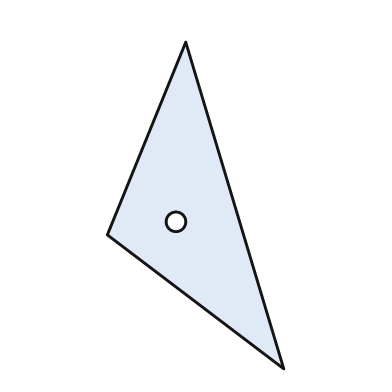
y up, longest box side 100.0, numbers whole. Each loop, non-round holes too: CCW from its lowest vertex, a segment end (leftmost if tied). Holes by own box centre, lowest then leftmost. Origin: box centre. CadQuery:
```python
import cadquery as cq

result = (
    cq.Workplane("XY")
    .moveTo(27.0, -50.0)
    .lineTo(-3.0, 50.0)
    .lineTo(-27.0, -9.0)
    .close()
    .moveTo(-6.0, -5.0)
    .circle(3.0)
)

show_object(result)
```